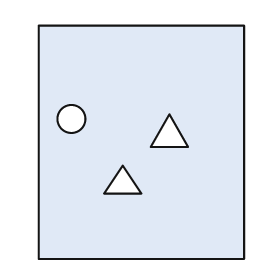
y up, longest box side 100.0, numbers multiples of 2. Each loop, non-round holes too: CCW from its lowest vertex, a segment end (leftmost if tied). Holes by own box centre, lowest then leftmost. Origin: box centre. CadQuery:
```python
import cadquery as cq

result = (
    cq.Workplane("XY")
    .moveTo(-44.0, -50.0)
    .lineTo(44.0, -50.0)
    .lineTo(44.0, 50.0)
    .lineTo(-44.0, 50.0)
    .close()
    .moveTo(-16.0, -22.0)
    .lineTo(0.0, -22.0)
    .lineTo(-8.0, -10.0)
    .close()
    .moveTo(4.0, -2.0)
    .lineTo(20.0, -2.0)
    .lineTo(12.0, 12.0)
    .close()
    .moveTo(-30.0, 10.0)
    .circle(6.0)
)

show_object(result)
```